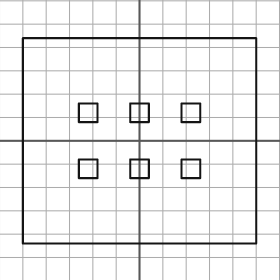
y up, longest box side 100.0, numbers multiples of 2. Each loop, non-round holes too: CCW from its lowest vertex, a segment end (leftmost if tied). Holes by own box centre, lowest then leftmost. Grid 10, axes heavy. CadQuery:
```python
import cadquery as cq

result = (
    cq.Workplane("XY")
    .moveTo(-50.0, -44.0)
    .lineTo(50.0, -44.0)
    .lineTo(50.0, 44.0)
    .lineTo(-50.0, 44.0)
    .close()
    .moveTo(-26.0, -16.0)
    .lineTo(-18.0, -16.0)
    .lineTo(-18.0, -8.0)
    .lineTo(-26.0, -8.0)
    .close()
    .moveTo(-4.0, -16.0)
    .lineTo(4.0, -16.0)
    .lineTo(4.0, -8.0)
    .lineTo(-4.0, -8.0)
    .close()
    .moveTo(18.0, -16.0)
    .lineTo(26.0, -16.0)
    .lineTo(26.0, -8.0)
    .lineTo(18.0, -8.0)
    .close()
    .moveTo(-26.0, 8.0)
    .lineTo(-18.0, 8.0)
    .lineTo(-18.0, 16.0)
    .lineTo(-26.0, 16.0)
    .close()
    .moveTo(-4.0, 8.0)
    .lineTo(4.0, 8.0)
    .lineTo(4.0, 16.0)
    .lineTo(-4.0, 16.0)
    .close()
    .moveTo(18.0, 8.0)
    .lineTo(26.0, 8.0)
    .lineTo(26.0, 16.0)
    .lineTo(18.0, 16.0)
    .close()
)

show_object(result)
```